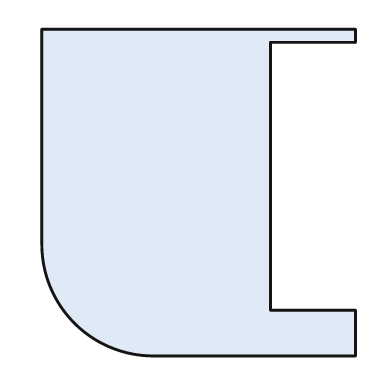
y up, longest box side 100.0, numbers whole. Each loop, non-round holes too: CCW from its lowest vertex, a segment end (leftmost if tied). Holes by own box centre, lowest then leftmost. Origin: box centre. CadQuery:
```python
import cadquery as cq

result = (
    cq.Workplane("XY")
    .moveTo(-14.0, -50.0)
    .lineTo(48.0, -50.0)
    .lineTo(48.0, -36.0)
    .lineTo(22.0, -36.0)
    .lineTo(22.0, 46.0)
    .lineTo(48.0, 46.0)
    .lineTo(48.0, 50.0)
    .lineTo(-48.0, 50.0)
    .lineTo(-48.0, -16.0)
    .threePointArc((-38.0, -40.0), (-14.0, -50.0))
    .close()
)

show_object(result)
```